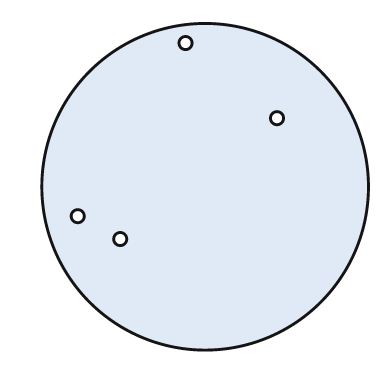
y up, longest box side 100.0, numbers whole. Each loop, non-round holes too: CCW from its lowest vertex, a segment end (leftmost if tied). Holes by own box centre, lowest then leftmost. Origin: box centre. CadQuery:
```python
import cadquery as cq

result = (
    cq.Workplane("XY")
    .moveTo(0.0, 0.0)
    .circle(50.0)
    .moveTo(-26.0, -16.0)
    .circle(2.0)
    .moveTo(-39.0, -9.0)
    .circle(2.0)
    .moveTo(22.0, 21.0)
    .circle(2.0)
    .moveTo(-6.0, 44.0)
    .circle(2.0)
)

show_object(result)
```